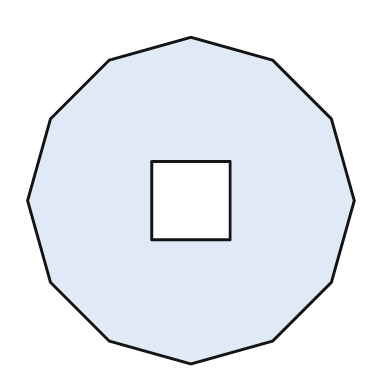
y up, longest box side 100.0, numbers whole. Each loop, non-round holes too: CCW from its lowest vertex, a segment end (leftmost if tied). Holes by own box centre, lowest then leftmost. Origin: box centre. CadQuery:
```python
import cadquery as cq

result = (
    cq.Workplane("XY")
    .moveTo(0.0, -50.0)
    .lineTo(25.0, -43.0)
    .lineTo(43.0, -25.0)
    .lineTo(50.0, 0.0)
    .lineTo(43.0, 25.0)
    .lineTo(25.0, 43.0)
    .lineTo(0.0, 50.0)
    .lineTo(-25.0, 43.0)
    .lineTo(-43.0, 25.0)
    .lineTo(-50.0, 0.0)
    .lineTo(-43.0, -25.0)
    .lineTo(-25.0, -43.0)
    .close()
    .moveTo(-12.0, -12.0)
    .lineTo(12.0, -12.0)
    .lineTo(12.0, 12.0)
    .lineTo(-12.0, 12.0)
    .close()
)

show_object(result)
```